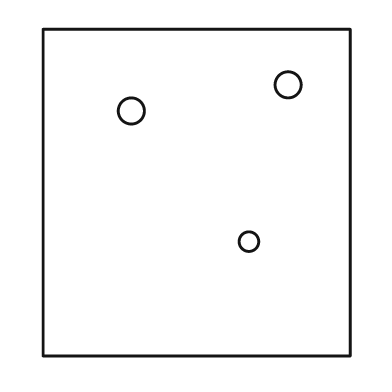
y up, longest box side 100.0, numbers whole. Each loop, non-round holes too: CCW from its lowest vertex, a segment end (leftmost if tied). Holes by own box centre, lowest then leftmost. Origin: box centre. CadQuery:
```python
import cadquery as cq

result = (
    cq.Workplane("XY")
    .moveTo(-47.0, -50.0)
    .lineTo(47.0, -50.0)
    .lineTo(47.0, 50.0)
    .lineTo(-47.0, 50.0)
    .close()
    .moveTo(16.0, -15.0)
    .circle(3.0)
    .moveTo(-20.0, 25.0)
    .circle(4.0)
    .moveTo(28.0, 33.0)
    .circle(4.0)
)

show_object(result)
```